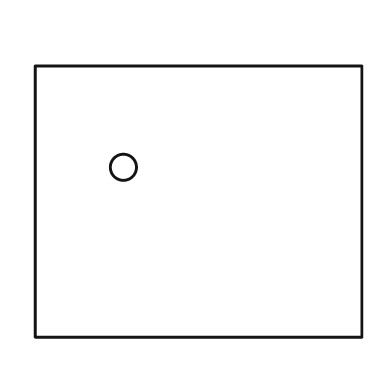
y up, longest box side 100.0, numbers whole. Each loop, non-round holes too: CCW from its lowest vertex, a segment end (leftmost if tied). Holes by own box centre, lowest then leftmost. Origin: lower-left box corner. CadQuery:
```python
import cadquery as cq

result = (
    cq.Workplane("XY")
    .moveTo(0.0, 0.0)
    .lineTo(100.0, 0.0)
    .lineTo(100.0, 83.0)
    .lineTo(0.0, 83.0)
    .close()
    .moveTo(27.0, 52.0)
    .circle(4.0)
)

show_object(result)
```